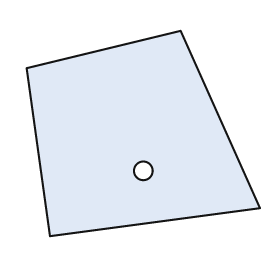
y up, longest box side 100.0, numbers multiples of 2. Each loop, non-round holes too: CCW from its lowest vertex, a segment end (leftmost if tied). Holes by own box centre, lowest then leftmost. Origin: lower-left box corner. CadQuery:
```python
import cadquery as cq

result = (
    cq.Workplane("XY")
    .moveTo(10.0, 0.0)
    .lineTo(100.0, 12.0)
    .lineTo(66.0, 88.0)
    .lineTo(0.0, 72.0)
    .close()
    .moveTo(50.0, 28.0)
    .circle(4.0)
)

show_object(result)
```